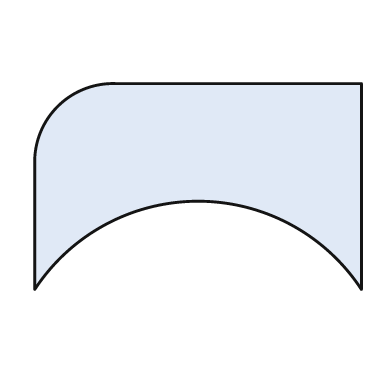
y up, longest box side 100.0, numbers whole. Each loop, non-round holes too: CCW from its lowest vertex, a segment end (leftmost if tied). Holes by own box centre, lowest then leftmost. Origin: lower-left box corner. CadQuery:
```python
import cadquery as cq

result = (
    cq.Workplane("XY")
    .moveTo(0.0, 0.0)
    .threePointArc((50.0, 27.0), (100.0, 0.0))
    .lineTo(100.0, 63.0)
    .lineTo(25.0, 63.0)
    .threePointArc((7.0, 56.0), (0.0, 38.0))
    .close()
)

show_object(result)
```